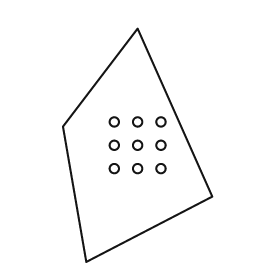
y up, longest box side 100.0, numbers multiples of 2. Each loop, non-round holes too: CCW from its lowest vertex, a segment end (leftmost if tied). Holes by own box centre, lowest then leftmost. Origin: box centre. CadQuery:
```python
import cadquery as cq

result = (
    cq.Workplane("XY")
    .moveTo(-22.0, -50.0)
    .lineTo(32.0, -22.0)
    .lineTo(0.0, 50.0)
    .lineTo(-32.0, 8.0)
    .close()
    .moveTo(-10.0, -10.0)
    .circle(2.0)
    .moveTo(0.0, -10.0)
    .circle(2.0)
    .moveTo(10.0, -10.0)
    .circle(2.0)
    .moveTo(-10.0, 0.0)
    .circle(2.0)
    .moveTo(0.0, 0.0)
    .circle(2.0)
    .moveTo(10.0, 0.0)
    .circle(2.0)
    .moveTo(-10.0, 10.0)
    .circle(2.0)
    .moveTo(0.0, 10.0)
    .circle(2.0)
    .moveTo(10.0, 10.0)
    .circle(2.0)
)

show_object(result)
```